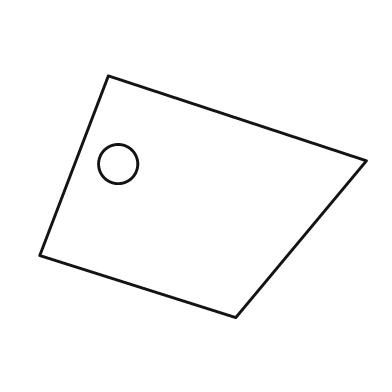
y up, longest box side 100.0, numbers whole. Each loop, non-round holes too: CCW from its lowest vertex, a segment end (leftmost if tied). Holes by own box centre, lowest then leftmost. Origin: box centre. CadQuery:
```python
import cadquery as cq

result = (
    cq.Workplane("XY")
    .moveTo(10.0, -37.0)
    .lineTo(50.0, 11.0)
    .lineTo(-29.0, 37.0)
    .lineTo(-50.0, -18.0)
    .close()
    .moveTo(-26.0, 10.0)
    .circle(6.0)
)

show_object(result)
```